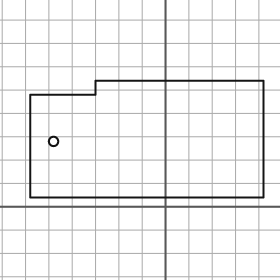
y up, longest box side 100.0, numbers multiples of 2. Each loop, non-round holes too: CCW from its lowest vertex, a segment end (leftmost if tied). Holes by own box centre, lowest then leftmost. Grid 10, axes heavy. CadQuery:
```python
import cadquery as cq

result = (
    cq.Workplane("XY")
    .moveTo(-58.0, 4.0)
    .lineTo(42.0, 4.0)
    .lineTo(42.0, 54.0)
    .lineTo(-30.0, 54.0)
    .lineTo(-30.0, 48.0)
    .lineTo(-58.0, 48.0)
    .close()
    .moveTo(-48.0, 28.0)
    .circle(2.0)
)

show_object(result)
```